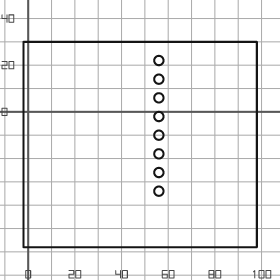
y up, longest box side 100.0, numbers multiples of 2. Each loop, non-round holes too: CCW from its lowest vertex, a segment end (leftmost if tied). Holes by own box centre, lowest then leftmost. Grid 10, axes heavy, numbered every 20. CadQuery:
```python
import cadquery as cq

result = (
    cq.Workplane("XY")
    .moveTo(-2.0, -58.0)
    .lineTo(98.0, -58.0)
    .lineTo(98.0, 30.0)
    .lineTo(-2.0, 30.0)
    .close()
    .moveTo(56.0, -34.0)
    .circle(2.0)
    .moveTo(56.0, -26.0)
    .circle(2.0)
    .moveTo(56.0, -18.0)
    .circle(2.0)
    .moveTo(56.0, -10.0)
    .circle(2.0)
    .moveTo(56.0, -2.0)
    .circle(2.0)
    .moveTo(56.0, 6.0)
    .circle(2.0)
    .moveTo(56.0, 14.0)
    .circle(2.0)
    .moveTo(56.0, 22.0)
    .circle(2.0)
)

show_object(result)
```